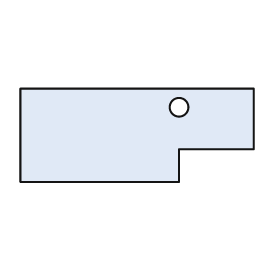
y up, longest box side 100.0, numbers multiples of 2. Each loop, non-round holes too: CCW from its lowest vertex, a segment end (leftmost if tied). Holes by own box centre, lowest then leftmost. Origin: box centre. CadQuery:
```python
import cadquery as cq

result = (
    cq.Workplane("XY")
    .moveTo(-50.0, -20.0)
    .lineTo(18.0, -20.0)
    .lineTo(18.0, -6.0)
    .lineTo(50.0, -6.0)
    .lineTo(50.0, 20.0)
    .lineTo(-50.0, 20.0)
    .close()
    .moveTo(18.0, 12.0)
    .circle(4.0)
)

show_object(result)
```